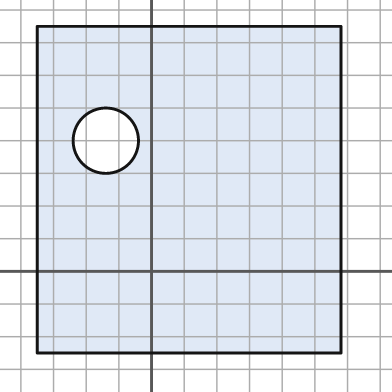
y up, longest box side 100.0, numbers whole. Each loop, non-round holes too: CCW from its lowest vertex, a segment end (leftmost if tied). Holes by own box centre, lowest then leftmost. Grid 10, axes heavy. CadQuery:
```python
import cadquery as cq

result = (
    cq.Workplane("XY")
    .moveTo(-35.0, -25.0)
    .lineTo(58.0, -25.0)
    .lineTo(58.0, 75.0)
    .lineTo(-35.0, 75.0)
    .close()
    .moveTo(-14.0, 40.0)
    .circle(10.0)
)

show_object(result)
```